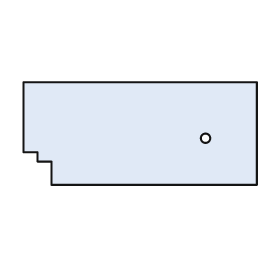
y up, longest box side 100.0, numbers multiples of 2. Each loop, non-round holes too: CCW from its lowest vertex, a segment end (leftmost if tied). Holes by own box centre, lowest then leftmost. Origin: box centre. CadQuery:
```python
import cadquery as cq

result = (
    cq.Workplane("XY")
    .moveTo(-38.0, -22.0)
    .lineTo(50.0, -22.0)
    .lineTo(50.0, 22.0)
    .lineTo(-50.0, 22.0)
    .lineTo(-50.0, -8.0)
    .lineTo(-44.0, -8.0)
    .lineTo(-44.0, -12.0)
    .lineTo(-38.0, -12.0)
    .close()
    .moveTo(28.0, -2.0)
    .circle(2.0)
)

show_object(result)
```